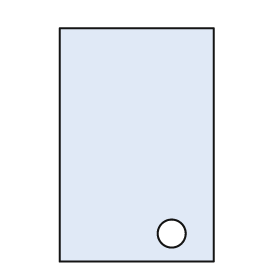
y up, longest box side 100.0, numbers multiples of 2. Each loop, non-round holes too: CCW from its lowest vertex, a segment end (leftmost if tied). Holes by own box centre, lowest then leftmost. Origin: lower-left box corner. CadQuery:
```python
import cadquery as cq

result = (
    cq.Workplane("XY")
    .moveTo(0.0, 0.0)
    .lineTo(66.0, 0.0)
    .lineTo(66.0, 100.0)
    .lineTo(0.0, 100.0)
    .close()
    .moveTo(48.0, 12.0)
    .circle(6.0)
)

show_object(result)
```